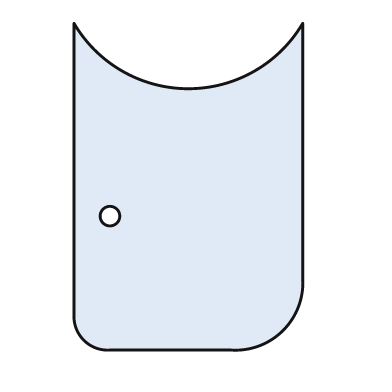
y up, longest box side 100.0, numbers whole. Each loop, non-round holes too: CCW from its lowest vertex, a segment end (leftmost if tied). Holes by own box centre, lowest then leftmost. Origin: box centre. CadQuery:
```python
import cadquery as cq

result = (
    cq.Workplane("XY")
    .moveTo(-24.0, -50.0)
    .lineTo(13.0, -50.0)
    .threePointArc((29.0, -44.0), (35.0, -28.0))
    .lineTo(35.0, 50.0)
    .threePointArc((0.0, 30.0), (-35.0, 50.0))
    .lineTo(-35.0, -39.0)
    .threePointArc((-32.0, -47.0), (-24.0, -50.0))
    .close()
    .moveTo(-24.0, -9.0)
    .circle(3.0)
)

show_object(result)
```